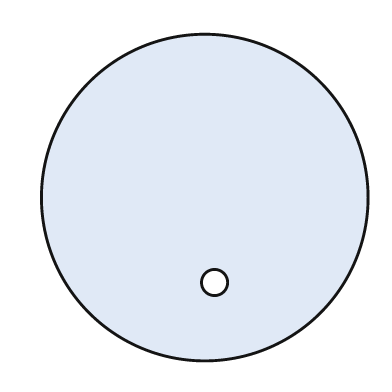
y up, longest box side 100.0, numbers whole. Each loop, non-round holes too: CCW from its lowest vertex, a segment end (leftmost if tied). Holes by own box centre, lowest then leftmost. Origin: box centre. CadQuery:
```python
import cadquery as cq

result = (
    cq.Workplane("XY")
    .moveTo(0.0, 0.0)
    .circle(50.0)
    .moveTo(3.0, -26.0)
    .circle(4.0)
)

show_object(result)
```